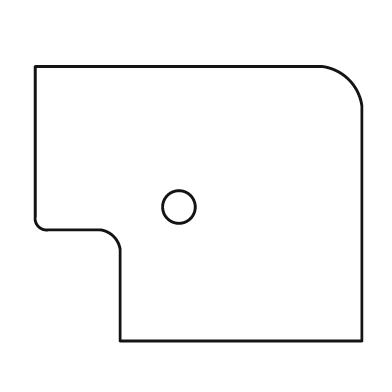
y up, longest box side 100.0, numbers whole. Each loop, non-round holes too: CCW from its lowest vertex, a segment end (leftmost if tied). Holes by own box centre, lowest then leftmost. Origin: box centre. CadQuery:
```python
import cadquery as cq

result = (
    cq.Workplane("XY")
    .moveTo(-24.0, -42.0)
    .lineTo(50.0, -42.0)
    .lineTo(50.0, 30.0)
    .threePointArc((46.0, 38.0), (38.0, 42.0))
    .lineTo(-50.0, 42.0)
    .lineTo(-50.0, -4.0)
    .threePointArc((-49.0, -7.0), (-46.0, -8.0))
    .lineTo(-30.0, -8.0)
    .threePointArc((-26.0, -10.0), (-24.0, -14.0))
    .close()
    .moveTo(-6.0, -1.0)
    .circle(5.0)
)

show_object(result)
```